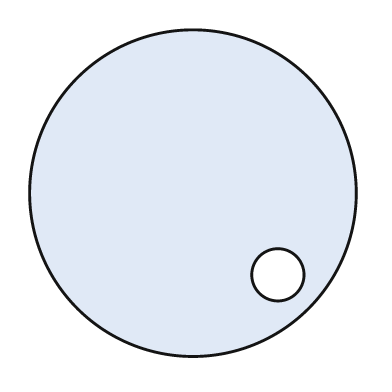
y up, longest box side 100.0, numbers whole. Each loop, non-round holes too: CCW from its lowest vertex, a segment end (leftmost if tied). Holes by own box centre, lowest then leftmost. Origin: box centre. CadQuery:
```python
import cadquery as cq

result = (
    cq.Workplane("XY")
    .moveTo(0.0, 0.0)
    .circle(50.0)
    .moveTo(26.0, -25.0)
    .circle(8.0)
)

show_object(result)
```